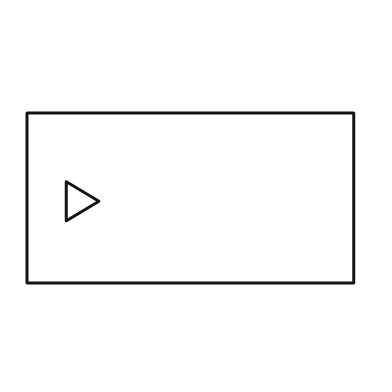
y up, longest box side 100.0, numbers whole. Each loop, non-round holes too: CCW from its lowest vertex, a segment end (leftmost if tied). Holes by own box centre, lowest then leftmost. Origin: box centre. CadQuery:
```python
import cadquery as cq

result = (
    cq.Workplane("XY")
    .moveTo(-50.0, -26.0)
    .lineTo(50.0, -26.0)
    .lineTo(50.0, 26.0)
    .lineTo(-50.0, 26.0)
    .close()
    .moveTo(-38.0, -7.0)
    .lineTo(-28.0, -1.0)
    .lineTo(-38.0, 5.0)
    .close()
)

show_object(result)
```